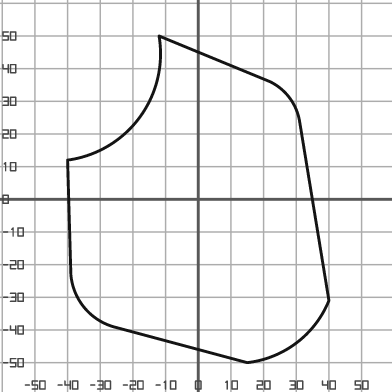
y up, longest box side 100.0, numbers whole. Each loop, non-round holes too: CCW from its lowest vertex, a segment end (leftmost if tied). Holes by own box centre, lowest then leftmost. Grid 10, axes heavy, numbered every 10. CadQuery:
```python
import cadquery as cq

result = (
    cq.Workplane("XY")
    .moveTo(15.0, -50.0)
    .threePointArc((30.0, -44.0), (40.0, -31.0))
    .lineTo(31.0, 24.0)
    .threePointArc((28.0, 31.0), (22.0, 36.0))
    .lineTo(-12.0, 50.0)
    .threePointArc((-18.0, 25.0), (-40.0, 12.0))
    .lineTo(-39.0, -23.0)
    .threePointArc((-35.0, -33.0), (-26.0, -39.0))
    .close()
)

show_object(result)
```